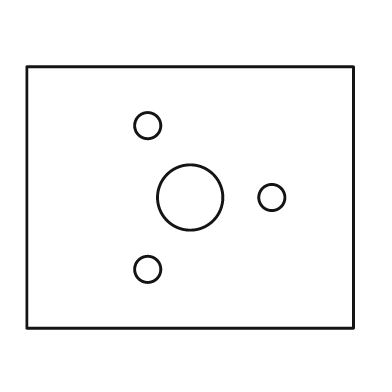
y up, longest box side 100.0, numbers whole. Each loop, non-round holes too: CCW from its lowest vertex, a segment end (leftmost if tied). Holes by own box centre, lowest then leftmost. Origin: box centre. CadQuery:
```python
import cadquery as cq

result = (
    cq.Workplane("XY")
    .moveTo(-50.0, -40.0)
    .lineTo(50.0, -40.0)
    .lineTo(50.0, 40.0)
    .lineTo(-50.0, 40.0)
    .close()
    .moveTo(-13.0, -22.0)
    .circle(4.0)
    .moveTo(0.0, 0.0)
    .circle(10.0)
    .moveTo(25.0, 0.0)
    .circle(4.0)
    .moveTo(-13.0, 22.0)
    .circle(4.0)
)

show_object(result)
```